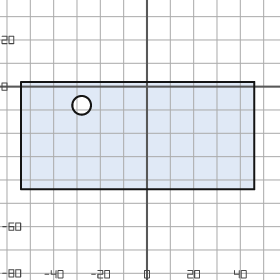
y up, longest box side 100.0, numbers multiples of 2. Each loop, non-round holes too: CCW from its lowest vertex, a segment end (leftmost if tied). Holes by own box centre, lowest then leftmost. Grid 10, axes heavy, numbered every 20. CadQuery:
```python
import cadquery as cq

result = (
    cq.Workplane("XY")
    .moveTo(-54.0, -44.0)
    .lineTo(46.0, -44.0)
    .lineTo(46.0, 2.0)
    .lineTo(-54.0, 2.0)
    .close()
    .moveTo(-28.0, -8.0)
    .circle(4.0)
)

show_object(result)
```